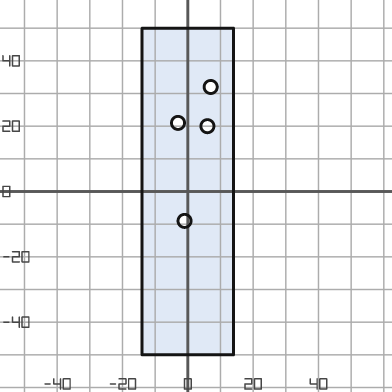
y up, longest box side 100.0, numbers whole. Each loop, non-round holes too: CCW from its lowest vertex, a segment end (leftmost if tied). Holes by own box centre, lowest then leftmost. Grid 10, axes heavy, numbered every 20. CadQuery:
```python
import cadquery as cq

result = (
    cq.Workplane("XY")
    .moveTo(-14.0, -50.0)
    .lineTo(14.0, -50.0)
    .lineTo(14.0, 50.0)
    .lineTo(-14.0, 50.0)
    .close()
    .moveTo(-1.0, -9.0)
    .circle(2.0)
    .moveTo(6.0, 20.0)
    .circle(2.0)
    .moveTo(-3.0, 21.0)
    .circle(2.0)
    .moveTo(7.0, 32.0)
    .circle(2.0)
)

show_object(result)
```